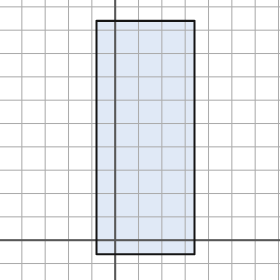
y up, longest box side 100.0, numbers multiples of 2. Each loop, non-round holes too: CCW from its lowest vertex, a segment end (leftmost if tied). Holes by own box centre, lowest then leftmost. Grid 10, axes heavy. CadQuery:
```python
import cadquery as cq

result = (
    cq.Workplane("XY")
    .moveTo(-8.0, -6.0)
    .lineTo(34.0, -6.0)
    .lineTo(34.0, 94.0)
    .lineTo(-8.0, 94.0)
    .close()
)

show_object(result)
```